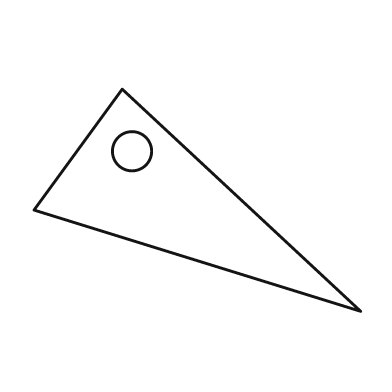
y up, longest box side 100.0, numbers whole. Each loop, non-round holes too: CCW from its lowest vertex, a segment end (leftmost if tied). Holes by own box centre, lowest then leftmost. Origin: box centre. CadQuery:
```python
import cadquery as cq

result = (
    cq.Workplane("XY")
    .moveTo(50.0, -34.0)
    .lineTo(-23.0, 34.0)
    .lineTo(-50.0, -3.0)
    .close()
    .moveTo(-20.0, 15.0)
    .circle(6.0)
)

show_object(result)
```